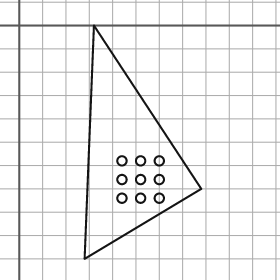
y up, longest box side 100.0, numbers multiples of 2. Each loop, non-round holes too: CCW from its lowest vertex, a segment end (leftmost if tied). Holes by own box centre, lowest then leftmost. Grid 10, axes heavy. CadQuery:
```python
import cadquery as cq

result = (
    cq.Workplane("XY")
    .moveTo(28.0, -100.0)
    .lineTo(78.0, -70.0)
    .lineTo(32.0, 0.0)
    .close()
    .moveTo(44.0, -74.0)
    .circle(2.0)
    .moveTo(52.0, -74.0)
    .circle(2.0)
    .moveTo(60.0, -74.0)
    .circle(2.0)
    .moveTo(44.0, -66.0)
    .circle(2.0)
    .moveTo(52.0, -66.0)
    .circle(2.0)
    .moveTo(60.0, -66.0)
    .circle(2.0)
    .moveTo(44.0, -58.0)
    .circle(2.0)
    .moveTo(52.0, -58.0)
    .circle(2.0)
    .moveTo(60.0, -58.0)
    .circle(2.0)
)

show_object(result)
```